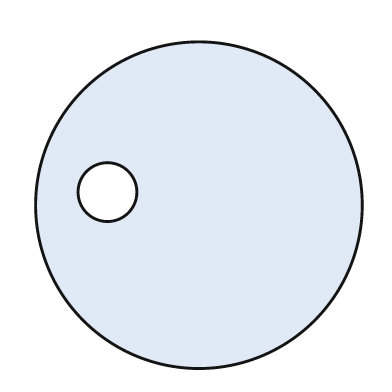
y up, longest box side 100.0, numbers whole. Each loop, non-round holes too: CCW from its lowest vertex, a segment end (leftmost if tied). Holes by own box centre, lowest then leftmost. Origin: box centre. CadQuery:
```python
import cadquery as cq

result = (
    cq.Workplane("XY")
    .moveTo(0.0, 0.0)
    .circle(50.0)
    .moveTo(-28.0, 4.0)
    .circle(9.0)
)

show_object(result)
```